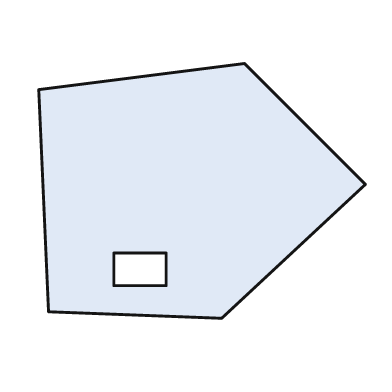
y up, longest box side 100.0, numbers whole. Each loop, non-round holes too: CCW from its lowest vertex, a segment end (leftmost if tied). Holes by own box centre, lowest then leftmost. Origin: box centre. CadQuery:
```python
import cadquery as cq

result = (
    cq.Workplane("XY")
    .moveTo(6.0, -39.0)
    .lineTo(50.0, 2.0)
    .lineTo(13.0, 39.0)
    .lineTo(-50.0, 31.0)
    .lineTo(-47.0, -37.0)
    .close()
    .moveTo(-27.0, -29.0)
    .lineTo(-11.0, -29.0)
    .lineTo(-11.0, -19.0)
    .lineTo(-27.0, -19.0)
    .close()
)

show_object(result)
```